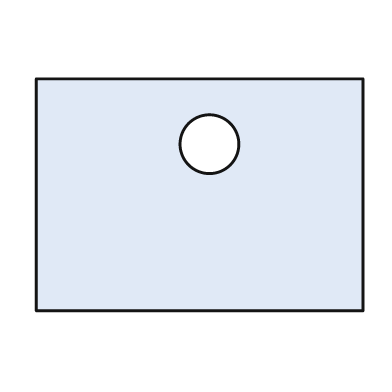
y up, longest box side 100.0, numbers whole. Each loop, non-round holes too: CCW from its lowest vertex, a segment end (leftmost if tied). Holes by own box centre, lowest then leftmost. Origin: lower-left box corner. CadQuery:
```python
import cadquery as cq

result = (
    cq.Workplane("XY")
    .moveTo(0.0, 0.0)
    .lineTo(100.0, 0.0)
    .lineTo(100.0, 71.0)
    .lineTo(0.0, 71.0)
    .close()
    .moveTo(53.0, 51.0)
    .circle(9.0)
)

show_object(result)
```